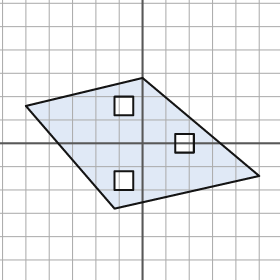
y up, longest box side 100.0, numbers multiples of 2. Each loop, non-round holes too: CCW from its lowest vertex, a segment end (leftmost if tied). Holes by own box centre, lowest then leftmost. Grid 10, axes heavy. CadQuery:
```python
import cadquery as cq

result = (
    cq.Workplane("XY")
    .moveTo(-12.0, -28.0)
    .lineTo(50.0, -14.0)
    .lineTo(0.0, 28.0)
    .lineTo(-50.0, 16.0)
    .close()
    .moveTo(-12.0, -20.0)
    .lineTo(-4.0, -20.0)
    .lineTo(-4.0, -12.0)
    .lineTo(-12.0, -12.0)
    .close()
    .moveTo(14.0, -4.0)
    .lineTo(22.0, -4.0)
    .lineTo(22.0, 4.0)
    .lineTo(14.0, 4.0)
    .close()
    .moveTo(-12.0, 12.0)
    .lineTo(-4.0, 12.0)
    .lineTo(-4.0, 20.0)
    .lineTo(-12.0, 20.0)
    .close()
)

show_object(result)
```